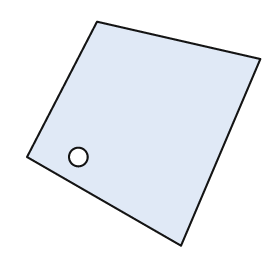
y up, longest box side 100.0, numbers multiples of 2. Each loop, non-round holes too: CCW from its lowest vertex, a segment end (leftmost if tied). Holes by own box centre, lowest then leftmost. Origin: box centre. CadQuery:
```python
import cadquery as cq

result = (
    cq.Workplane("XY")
    .moveTo(16.0, -48.0)
    .lineTo(50.0, 32.0)
    .lineTo(-20.0, 48.0)
    .lineTo(-50.0, -10.0)
    .close()
    .moveTo(-28.0, -10.0)
    .circle(4.0)
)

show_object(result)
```